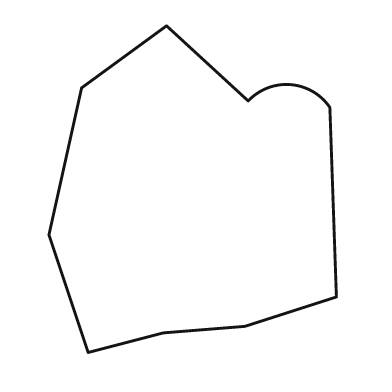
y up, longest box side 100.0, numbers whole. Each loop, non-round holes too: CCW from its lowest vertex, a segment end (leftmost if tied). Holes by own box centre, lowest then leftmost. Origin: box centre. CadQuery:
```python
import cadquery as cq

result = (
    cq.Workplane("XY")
    .moveTo(-32.0, -50.0)
    .lineTo(-9.0, -44.0)
    .lineTo(16.0, -42.0)
    .lineTo(44.0, -33.0)
    .lineTo(42.0, 25.0)
    .threePointArc((30.0, 32.0), (17.0, 27.0))
    .lineTo(-8.0, 50.0)
    .lineTo(-34.0, 31.0)
    .lineTo(-44.0, -14.0)
    .close()
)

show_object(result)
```